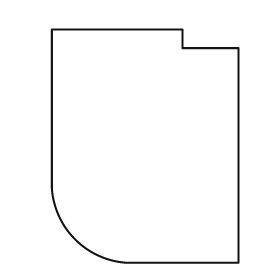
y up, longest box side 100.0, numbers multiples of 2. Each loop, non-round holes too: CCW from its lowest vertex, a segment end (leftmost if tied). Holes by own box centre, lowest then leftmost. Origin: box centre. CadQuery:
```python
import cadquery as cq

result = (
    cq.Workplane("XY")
    .moveTo(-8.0, -50.0)
    .lineTo(40.0, -50.0)
    .lineTo(40.0, 42.0)
    .lineTo(16.0, 42.0)
    .lineTo(16.0, 50.0)
    .lineTo(-40.0, 50.0)
    .lineTo(-40.0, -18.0)
    .threePointArc((-30.0, -40.0), (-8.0, -50.0))
    .close()
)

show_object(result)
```